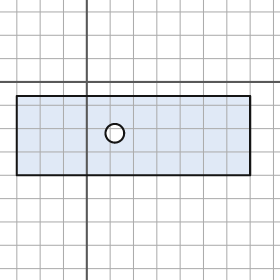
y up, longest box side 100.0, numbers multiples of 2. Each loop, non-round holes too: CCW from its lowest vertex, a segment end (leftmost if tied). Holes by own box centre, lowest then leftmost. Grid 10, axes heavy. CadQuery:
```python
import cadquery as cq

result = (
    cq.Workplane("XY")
    .moveTo(-30.0, -40.0)
    .lineTo(70.0, -40.0)
    .lineTo(70.0, -6.0)
    .lineTo(-30.0, -6.0)
    .close()
    .moveTo(12.0, -22.0)
    .circle(4.0)
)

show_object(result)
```